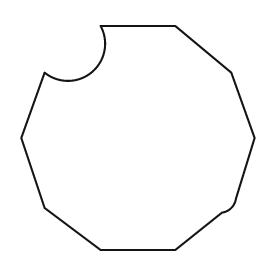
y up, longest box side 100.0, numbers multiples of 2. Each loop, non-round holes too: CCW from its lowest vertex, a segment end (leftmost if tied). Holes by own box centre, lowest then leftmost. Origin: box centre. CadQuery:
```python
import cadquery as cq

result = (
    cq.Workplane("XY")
    .moveTo(-16.0, -48.0)
    .lineTo(16.0, -48.0)
    .lineTo(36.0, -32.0)
    .threePointArc((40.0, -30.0), (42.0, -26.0))
    .lineTo(50.0, 0.0)
    .lineTo(40.0, 28.0)
    .lineTo(16.0, 48.0)
    .lineTo(-16.0, 48.0)
    .threePointArc((-20.0, 28.0), (-40.0, 28.0))
    .lineTo(-50.0, 0.0)
    .lineTo(-40.0, -30.0)
    .close()
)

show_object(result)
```